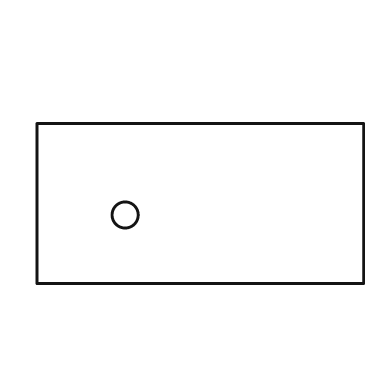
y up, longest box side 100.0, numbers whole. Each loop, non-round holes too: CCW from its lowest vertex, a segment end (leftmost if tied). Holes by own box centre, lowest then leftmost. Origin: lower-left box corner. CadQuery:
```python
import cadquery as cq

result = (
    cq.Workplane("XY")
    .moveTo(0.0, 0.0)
    .lineTo(100.0, 0.0)
    .lineTo(100.0, 49.0)
    .lineTo(0.0, 49.0)
    .close()
    .moveTo(27.0, 21.0)
    .circle(4.0)
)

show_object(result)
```